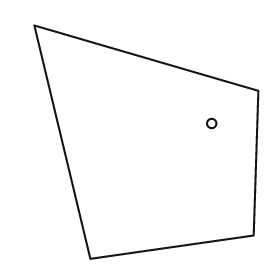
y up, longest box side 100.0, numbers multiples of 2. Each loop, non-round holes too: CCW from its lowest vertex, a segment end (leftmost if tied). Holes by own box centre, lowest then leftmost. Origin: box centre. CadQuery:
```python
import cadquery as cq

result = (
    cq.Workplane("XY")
    .moveTo(-24.0, -50.0)
    .lineTo(46.0, -40.0)
    .lineTo(48.0, 22.0)
    .lineTo(-48.0, 50.0)
    .close()
    .moveTo(28.0, 8.0)
    .circle(2.0)
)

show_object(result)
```